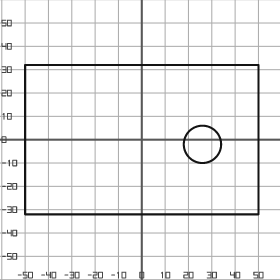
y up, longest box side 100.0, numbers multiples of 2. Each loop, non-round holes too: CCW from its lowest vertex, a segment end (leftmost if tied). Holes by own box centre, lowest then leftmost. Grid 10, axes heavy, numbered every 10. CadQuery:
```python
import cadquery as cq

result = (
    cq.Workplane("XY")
    .moveTo(-50.0, -32.0)
    .lineTo(50.0, -32.0)
    .lineTo(50.0, 32.0)
    .lineTo(-50.0, 32.0)
    .close()
    .moveTo(26.0, -2.0)
    .circle(8.0)
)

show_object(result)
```